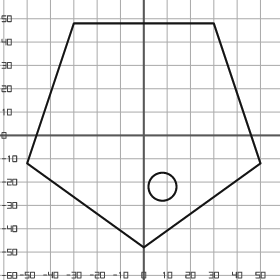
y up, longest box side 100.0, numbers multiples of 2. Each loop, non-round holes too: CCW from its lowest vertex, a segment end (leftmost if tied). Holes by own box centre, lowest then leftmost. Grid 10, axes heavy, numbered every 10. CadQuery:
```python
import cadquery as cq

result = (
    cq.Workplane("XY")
    .moveTo(0.0, -48.0)
    .lineTo(50.0, -12.0)
    .lineTo(30.0, 48.0)
    .lineTo(-30.0, 48.0)
    .lineTo(-50.0, -12.0)
    .close()
    .moveTo(8.0, -22.0)
    .circle(6.0)
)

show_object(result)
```